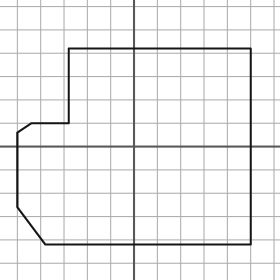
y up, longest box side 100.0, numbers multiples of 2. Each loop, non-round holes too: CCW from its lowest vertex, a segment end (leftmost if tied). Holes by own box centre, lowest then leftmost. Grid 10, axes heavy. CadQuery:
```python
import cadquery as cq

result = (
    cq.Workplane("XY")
    .moveTo(-38.0, -42.0)
    .lineTo(50.0, -42.0)
    .lineTo(50.0, 42.0)
    .lineTo(-28.0, 42.0)
    .lineTo(-28.0, 10.0)
    .lineTo(-44.0, 10.0)
    .lineTo(-50.0, 6.0)
    .lineTo(-50.0, -26.0)
    .close()
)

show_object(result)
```